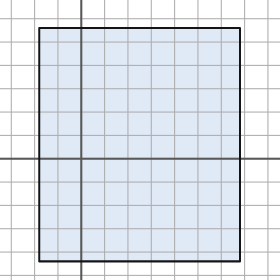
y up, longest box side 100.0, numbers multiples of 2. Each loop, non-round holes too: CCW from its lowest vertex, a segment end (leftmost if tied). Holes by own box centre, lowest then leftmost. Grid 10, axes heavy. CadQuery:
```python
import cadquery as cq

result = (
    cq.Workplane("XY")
    .moveTo(-18.0, -44.0)
    .lineTo(68.0, -44.0)
    .lineTo(68.0, 56.0)
    .lineTo(-18.0, 56.0)
    .close()
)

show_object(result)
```